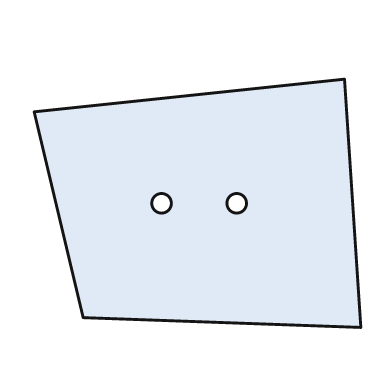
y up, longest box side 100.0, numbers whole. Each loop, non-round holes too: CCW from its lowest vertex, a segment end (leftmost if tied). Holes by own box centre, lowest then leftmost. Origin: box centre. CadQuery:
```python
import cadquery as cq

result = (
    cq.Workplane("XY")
    .moveTo(50.0, -38.0)
    .lineTo(45.0, 38.0)
    .lineTo(-50.0, 28.0)
    .lineTo(-35.0, -35.0)
    .close()
    .moveTo(-11.0, 0.0)
    .circle(3.0)
    .moveTo(12.0, 0.0)
    .circle(3.0)
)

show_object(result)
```